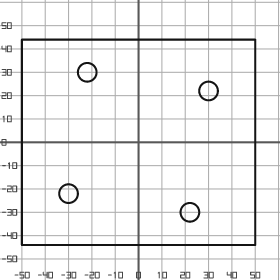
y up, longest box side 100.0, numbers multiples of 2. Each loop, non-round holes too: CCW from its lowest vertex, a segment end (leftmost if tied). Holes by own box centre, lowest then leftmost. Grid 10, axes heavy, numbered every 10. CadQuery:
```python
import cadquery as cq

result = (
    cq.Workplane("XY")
    .moveTo(-50.0, -44.0)
    .lineTo(50.0, -44.0)
    .lineTo(50.0, 44.0)
    .lineTo(-50.0, 44.0)
    .close()
    .moveTo(22.0, -30.0)
    .circle(4.0)
    .moveTo(-30.0, -22.0)
    .circle(4.0)
    .moveTo(30.0, 22.0)
    .circle(4.0)
    .moveTo(-22.0, 30.0)
    .circle(4.0)
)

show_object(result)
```